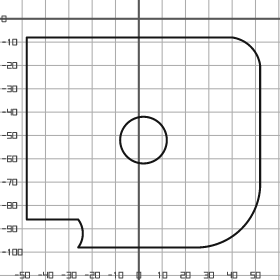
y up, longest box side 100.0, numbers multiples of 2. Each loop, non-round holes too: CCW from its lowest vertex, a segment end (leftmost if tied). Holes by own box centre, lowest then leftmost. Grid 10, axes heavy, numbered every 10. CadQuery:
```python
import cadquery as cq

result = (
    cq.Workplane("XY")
    .moveTo(-26.0, -98.0)
    .lineTo(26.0, -98.0)
    .threePointArc((44.0, -90.0), (52.0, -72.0))
    .lineTo(52.0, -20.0)
    .threePointArc((48.0, -12.0), (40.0, -8.0))
    .lineTo(-48.0, -8.0)
    .lineTo(-48.0, -86.0)
    .lineTo(-26.0, -86.0)
    .threePointArc((-24.0, -92.0), (-26.0, -98.0))
    .close()
    .moveTo(2.0, -52.0)
    .circle(10.0)
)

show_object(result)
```